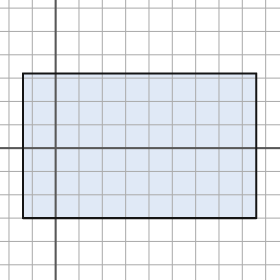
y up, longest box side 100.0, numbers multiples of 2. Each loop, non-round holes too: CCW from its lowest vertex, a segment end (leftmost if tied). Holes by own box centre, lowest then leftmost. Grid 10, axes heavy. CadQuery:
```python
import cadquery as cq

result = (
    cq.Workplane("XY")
    .moveTo(-14.0, -30.0)
    .lineTo(86.0, -30.0)
    .lineTo(86.0, 32.0)
    .lineTo(-14.0, 32.0)
    .close()
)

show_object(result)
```